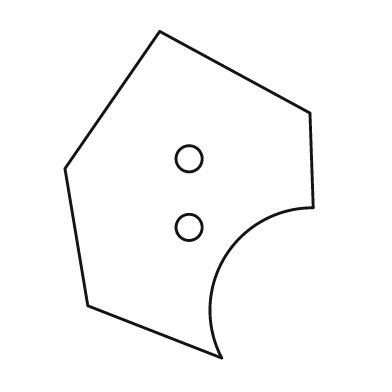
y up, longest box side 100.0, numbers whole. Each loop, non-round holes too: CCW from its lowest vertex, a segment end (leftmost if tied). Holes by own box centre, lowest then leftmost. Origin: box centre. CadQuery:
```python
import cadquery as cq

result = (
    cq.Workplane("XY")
    .moveTo(10.0, -50.0)
    .threePointArc((11.0, -19.0), (38.0, -4.0))
    .lineTo(37.0, 25.0)
    .lineTo(-9.0, 50.0)
    .lineTo(-38.0, 8.0)
    .lineTo(-31.0, -34.0)
    .close()
    .moveTo(0.0, -10.0)
    .circle(4.0)
    .moveTo(0.0, 11.0)
    .circle(4.0)
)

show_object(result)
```